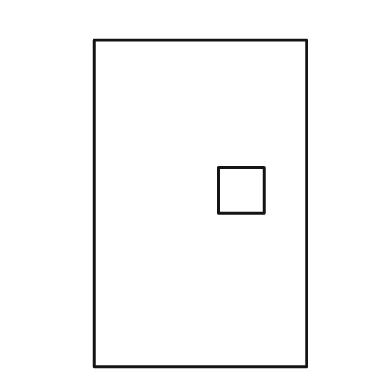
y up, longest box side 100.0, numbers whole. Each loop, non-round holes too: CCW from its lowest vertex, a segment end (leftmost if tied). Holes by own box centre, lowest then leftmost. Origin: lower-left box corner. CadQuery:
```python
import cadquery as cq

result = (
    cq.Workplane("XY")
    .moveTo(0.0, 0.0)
    .lineTo(65.0, 0.0)
    .lineTo(65.0, 100.0)
    .lineTo(0.0, 100.0)
    .close()
    .moveTo(38.0, 47.0)
    .lineTo(52.0, 47.0)
    .lineTo(52.0, 61.0)
    .lineTo(38.0, 61.0)
    .close()
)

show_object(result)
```